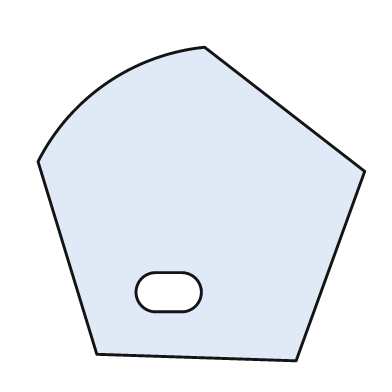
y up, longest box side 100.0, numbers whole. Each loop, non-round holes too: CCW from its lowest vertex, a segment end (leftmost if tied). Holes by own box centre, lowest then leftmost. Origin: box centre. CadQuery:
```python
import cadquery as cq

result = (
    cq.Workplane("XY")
    .moveTo(29.0, -48.0)
    .lineTo(50.0, 10.0)
    .lineTo(1.0, 48.0)
    .threePointArc((-29.0, 37.0), (-50.0, 13.0))
    .lineTo(-32.0, -46.0)
    .close()
    .moveTo(-14.0, -33.0)
    .lineTo(-6.0, -33.0)
    .threePointArc((0.0, -27.0), (-6.0, -21.0))
    .lineTo(-14.0, -21.0)
    .threePointArc((-20.0, -27.0), (-14.0, -33.0))
    .close()
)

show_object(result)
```